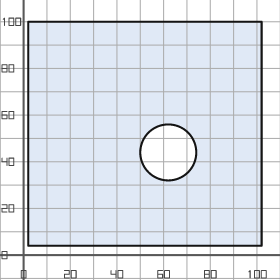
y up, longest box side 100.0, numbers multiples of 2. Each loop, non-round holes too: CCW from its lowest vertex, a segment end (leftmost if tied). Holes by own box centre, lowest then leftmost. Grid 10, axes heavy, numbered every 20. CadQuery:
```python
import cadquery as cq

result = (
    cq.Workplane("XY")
    .moveTo(2.0, 4.0)
    .lineTo(102.0, 4.0)
    .lineTo(102.0, 100.0)
    .lineTo(2.0, 100.0)
    .close()
    .moveTo(62.0, 44.0)
    .circle(12.0)
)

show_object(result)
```